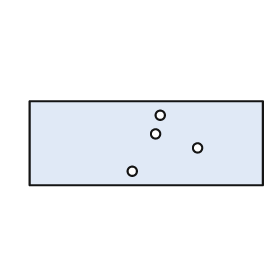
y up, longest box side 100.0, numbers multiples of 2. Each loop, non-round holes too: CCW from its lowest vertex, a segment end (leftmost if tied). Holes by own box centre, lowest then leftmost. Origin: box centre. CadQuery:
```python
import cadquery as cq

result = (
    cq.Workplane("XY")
    .moveTo(-50.0, -18.0)
    .lineTo(50.0, -18.0)
    .lineTo(50.0, 18.0)
    .lineTo(-50.0, 18.0)
    .close()
    .moveTo(-6.0, -12.0)
    .circle(2.0)
    .moveTo(22.0, -2.0)
    .circle(2.0)
    .moveTo(4.0, 4.0)
    .circle(2.0)
    .moveTo(6.0, 12.0)
    .circle(2.0)
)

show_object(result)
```